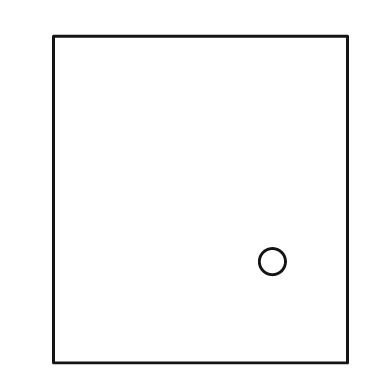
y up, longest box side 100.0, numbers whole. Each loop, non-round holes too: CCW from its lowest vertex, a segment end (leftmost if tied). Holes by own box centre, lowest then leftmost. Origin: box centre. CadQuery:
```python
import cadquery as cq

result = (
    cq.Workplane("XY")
    .moveTo(-45.0, -50.0)
    .lineTo(45.0, -50.0)
    .lineTo(45.0, 50.0)
    .lineTo(-45.0, 50.0)
    .close()
    .moveTo(22.0, -19.0)
    .circle(4.0)
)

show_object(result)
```